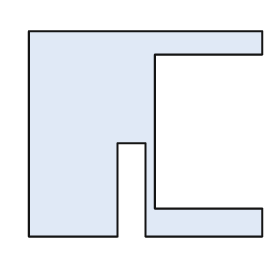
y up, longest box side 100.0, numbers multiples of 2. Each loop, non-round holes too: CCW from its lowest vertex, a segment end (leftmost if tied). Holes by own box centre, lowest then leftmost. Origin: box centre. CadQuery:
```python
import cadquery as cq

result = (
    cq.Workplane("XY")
    .moveTo(-50.0, -44.0)
    .lineTo(-12.0, -44.0)
    .lineTo(-12.0, -4.0)
    .lineTo(0.0, -4.0)
    .lineTo(0.0, -44.0)
    .lineTo(50.0, -44.0)
    .lineTo(50.0, -32.0)
    .lineTo(4.0, -32.0)
    .lineTo(4.0, 34.0)
    .lineTo(50.0, 34.0)
    .lineTo(50.0, 44.0)
    .lineTo(-50.0, 44.0)
    .close()
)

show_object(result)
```